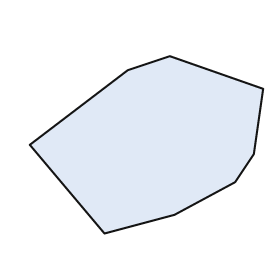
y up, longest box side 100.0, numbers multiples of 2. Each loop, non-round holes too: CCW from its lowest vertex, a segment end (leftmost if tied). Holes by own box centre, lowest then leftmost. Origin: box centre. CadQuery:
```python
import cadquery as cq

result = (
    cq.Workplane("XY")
    .moveTo(-18.0, -38.0)
    .lineTo(12.0, -30.0)
    .lineTo(38.0, -16.0)
    .lineTo(46.0, -4.0)
    .lineTo(50.0, 24.0)
    .lineTo(10.0, 38.0)
    .lineTo(-8.0, 32.0)
    .lineTo(-50.0, 0.0)
    .close()
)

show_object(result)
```